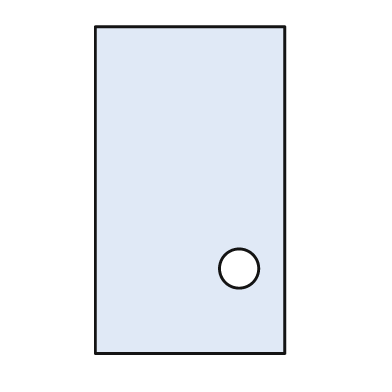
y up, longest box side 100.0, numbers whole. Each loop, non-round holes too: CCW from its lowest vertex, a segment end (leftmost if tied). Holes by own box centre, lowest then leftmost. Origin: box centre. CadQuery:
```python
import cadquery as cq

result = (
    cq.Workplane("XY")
    .moveTo(-29.0, -50.0)
    .lineTo(29.0, -50.0)
    .lineTo(29.0, 50.0)
    .lineTo(-29.0, 50.0)
    .close()
    .moveTo(15.0, -24.0)
    .circle(6.0)
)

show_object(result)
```